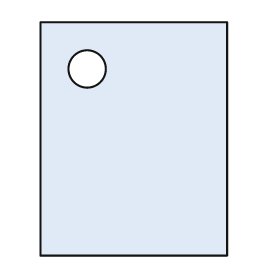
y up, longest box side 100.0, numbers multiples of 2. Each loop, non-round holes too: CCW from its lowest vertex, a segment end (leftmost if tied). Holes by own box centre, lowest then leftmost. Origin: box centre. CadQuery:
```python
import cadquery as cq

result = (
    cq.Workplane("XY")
    .moveTo(-40.0, -50.0)
    .lineTo(40.0, -50.0)
    .lineTo(40.0, 50.0)
    .lineTo(-40.0, 50.0)
    .close()
    .moveTo(-20.0, 30.0)
    .circle(8.0)
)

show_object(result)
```